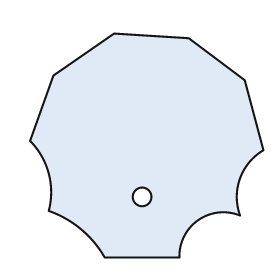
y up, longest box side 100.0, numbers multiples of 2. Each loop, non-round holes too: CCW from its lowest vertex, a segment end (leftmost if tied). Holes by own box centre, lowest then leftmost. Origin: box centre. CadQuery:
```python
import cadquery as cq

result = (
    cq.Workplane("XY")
    .moveTo(-18.0, -48.0)
    .lineTo(14.0, -48.0)
    .threePointArc((22.0, -32.0), (40.0, -30.0))
    .threePointArc((40.0, -14.0), (50.0, -2.0))
    .lineTo(42.0, 28.0)
    .lineTo(18.0, 46.0)
    .lineTo(-14.0, 48.0)
    .lineTo(-40.0, 30.0)
    .lineTo(-50.0, 2.0)
    .threePointArc((-42.0, -12.0), (-42.0, -28.0))
    .threePointArc((-28.0, -36.0), (-18.0, -48.0))
    .close()
    .moveTo(-2.0, -22.0)
    .circle(4.0)
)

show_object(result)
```